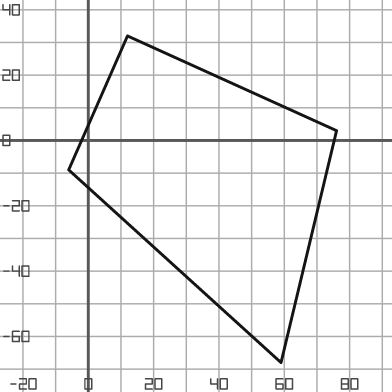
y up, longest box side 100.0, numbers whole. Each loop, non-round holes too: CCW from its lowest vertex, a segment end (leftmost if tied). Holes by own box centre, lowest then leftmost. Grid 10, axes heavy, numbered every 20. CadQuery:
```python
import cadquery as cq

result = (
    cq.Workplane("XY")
    .moveTo(59.0, -68.0)
    .lineTo(76.0, 3.0)
    .lineTo(12.0, 32.0)
    .lineTo(-6.0, -9.0)
    .close()
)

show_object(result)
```